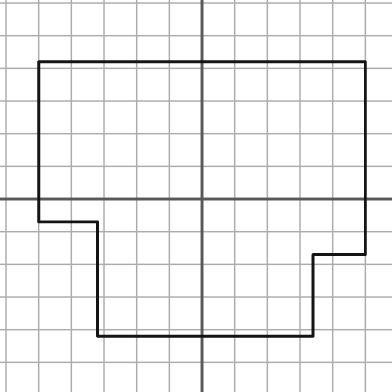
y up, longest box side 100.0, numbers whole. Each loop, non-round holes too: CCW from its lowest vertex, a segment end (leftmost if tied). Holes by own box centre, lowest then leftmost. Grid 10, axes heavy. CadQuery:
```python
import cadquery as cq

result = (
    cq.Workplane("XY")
    .moveTo(-32.0, -42.0)
    .lineTo(34.0, -42.0)
    .lineTo(34.0, -17.0)
    .lineTo(50.0, -17.0)
    .lineTo(50.0, 42.0)
    .lineTo(-50.0, 42.0)
    .lineTo(-50.0, -7.0)
    .lineTo(-32.0, -7.0)
    .close()
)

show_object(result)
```